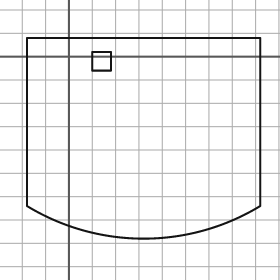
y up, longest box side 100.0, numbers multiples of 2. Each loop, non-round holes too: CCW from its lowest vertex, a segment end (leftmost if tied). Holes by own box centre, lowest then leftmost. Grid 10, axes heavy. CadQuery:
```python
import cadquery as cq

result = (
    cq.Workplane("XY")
    .moveTo(-18.0, -64.0)
    .threePointArc((32.0, -78.0), (82.0, -64.0))
    .lineTo(82.0, 8.0)
    .lineTo(-18.0, 8.0)
    .close()
    .moveTo(10.0, -6.0)
    .lineTo(18.0, -6.0)
    .lineTo(18.0, 2.0)
    .lineTo(10.0, 2.0)
    .close()
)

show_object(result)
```